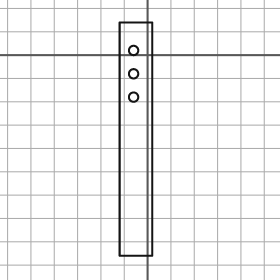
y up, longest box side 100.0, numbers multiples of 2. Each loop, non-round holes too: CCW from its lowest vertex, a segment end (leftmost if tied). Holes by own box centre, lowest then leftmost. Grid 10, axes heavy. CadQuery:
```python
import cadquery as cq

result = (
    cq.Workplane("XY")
    .moveTo(-12.0, -86.0)
    .lineTo(2.0, -86.0)
    .lineTo(2.0, 14.0)
    .lineTo(-12.0, 14.0)
    .close()
    .moveTo(-6.0, -18.0)
    .circle(2.0)
    .moveTo(-6.0, -8.0)
    .circle(2.0)
    .moveTo(-6.0, 2.0)
    .circle(2.0)
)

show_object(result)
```